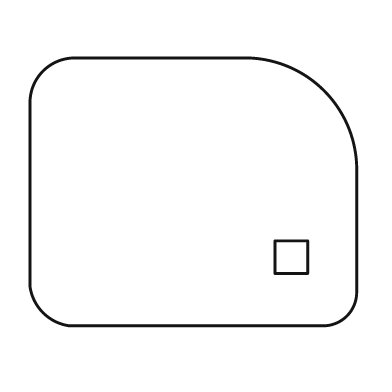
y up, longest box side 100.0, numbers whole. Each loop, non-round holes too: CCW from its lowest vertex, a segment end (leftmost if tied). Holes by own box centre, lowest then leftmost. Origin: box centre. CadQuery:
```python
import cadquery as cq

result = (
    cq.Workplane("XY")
    .moveTo(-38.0, -41.0)
    .lineTo(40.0, -41.0)
    .threePointArc((47.0, -38.0), (50.0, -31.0))
    .lineTo(50.0, 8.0)
    .threePointArc((40.0, 31.0), (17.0, 41.0))
    .lineTo(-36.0, 41.0)
    .threePointArc((-46.0, 37.0), (-50.0, 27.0))
    .lineTo(-50.0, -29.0)
    .threePointArc((-46.0, -37.0), (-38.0, -41.0))
    .close()
    .moveTo(25.0, -25.0)
    .lineTo(35.0, -25.0)
    .lineTo(35.0, -15.0)
    .lineTo(25.0, -15.0)
    .close()
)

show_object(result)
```